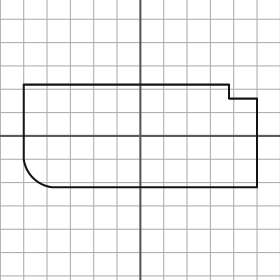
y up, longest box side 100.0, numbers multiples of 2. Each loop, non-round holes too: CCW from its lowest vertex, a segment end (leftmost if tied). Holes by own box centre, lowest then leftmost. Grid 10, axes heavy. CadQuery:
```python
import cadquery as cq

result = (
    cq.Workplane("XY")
    .moveTo(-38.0, -22.0)
    .lineTo(50.0, -22.0)
    .lineTo(50.0, 16.0)
    .lineTo(38.0, 16.0)
    .lineTo(38.0, 22.0)
    .lineTo(-50.0, 22.0)
    .lineTo(-50.0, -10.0)
    .threePointArc((-46.0, -18.0), (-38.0, -22.0))
    .close()
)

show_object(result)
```